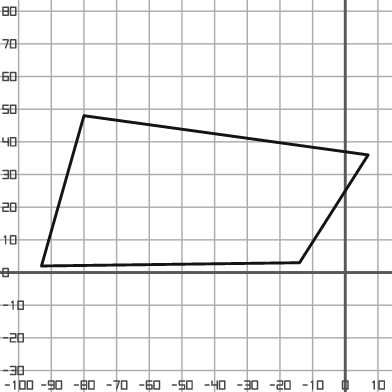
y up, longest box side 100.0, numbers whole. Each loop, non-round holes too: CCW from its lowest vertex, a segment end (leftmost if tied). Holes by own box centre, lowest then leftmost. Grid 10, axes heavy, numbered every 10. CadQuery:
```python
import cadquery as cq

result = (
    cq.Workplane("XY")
    .moveTo(-93.0, 2.0)
    .lineTo(-14.0, 3.0)
    .lineTo(7.0, 36.0)
    .lineTo(-80.0, 48.0)
    .close()
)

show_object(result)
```